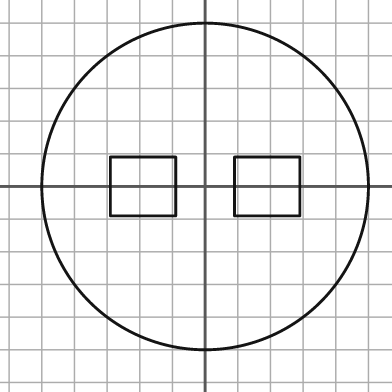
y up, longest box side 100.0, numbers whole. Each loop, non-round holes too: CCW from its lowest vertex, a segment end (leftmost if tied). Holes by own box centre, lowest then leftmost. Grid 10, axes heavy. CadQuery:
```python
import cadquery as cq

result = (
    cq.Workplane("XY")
    .moveTo(0.0, 0.0)
    .circle(50.0)
    .moveTo(-29.0, -9.0)
    .lineTo(-9.0, -9.0)
    .lineTo(-9.0, 9.0)
    .lineTo(-29.0, 9.0)
    .close()
    .moveTo(9.0, -9.0)
    .lineTo(29.0, -9.0)
    .lineTo(29.0, 9.0)
    .lineTo(9.0, 9.0)
    .close()
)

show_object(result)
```